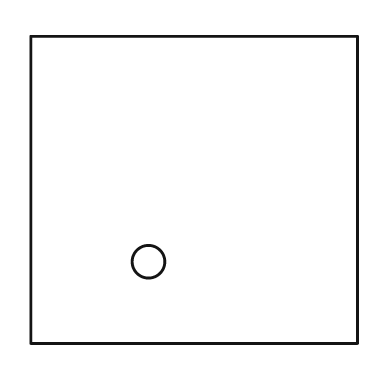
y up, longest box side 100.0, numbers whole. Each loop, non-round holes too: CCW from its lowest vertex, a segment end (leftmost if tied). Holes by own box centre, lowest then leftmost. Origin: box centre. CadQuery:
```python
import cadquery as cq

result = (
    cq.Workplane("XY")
    .moveTo(-50.0, -47.0)
    .lineTo(50.0, -47.0)
    .lineTo(50.0, 47.0)
    .lineTo(-50.0, 47.0)
    .close()
    .moveTo(-14.0, -22.0)
    .circle(5.0)
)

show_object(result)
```